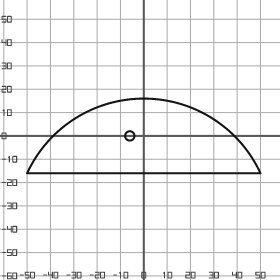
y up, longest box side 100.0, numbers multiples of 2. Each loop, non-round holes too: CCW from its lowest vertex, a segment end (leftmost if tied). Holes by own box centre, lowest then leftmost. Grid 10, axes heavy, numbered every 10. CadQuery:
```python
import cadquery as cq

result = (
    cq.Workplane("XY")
    .moveTo(-50.0, -16.0)
    .lineTo(50.0, -16.0)
    .threePointArc((0.0, 16.0), (-50.0, -16.0))
    .close()
    .moveTo(-6.0, 0.0)
    .circle(2.0)
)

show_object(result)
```